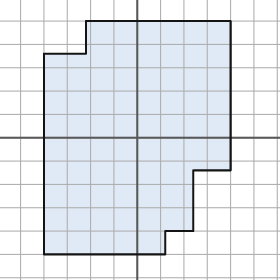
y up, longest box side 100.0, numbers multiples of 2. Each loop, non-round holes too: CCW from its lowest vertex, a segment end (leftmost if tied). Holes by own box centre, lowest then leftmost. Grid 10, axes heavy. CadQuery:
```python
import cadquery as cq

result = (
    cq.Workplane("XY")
    .moveTo(-40.0, -50.0)
    .lineTo(12.0, -50.0)
    .lineTo(12.0, -40.0)
    .lineTo(24.0, -40.0)
    .lineTo(24.0, -14.0)
    .lineTo(40.0, -14.0)
    .lineTo(40.0, 50.0)
    .lineTo(-22.0, 50.0)
    .lineTo(-22.0, 36.0)
    .lineTo(-40.0, 36.0)
    .close()
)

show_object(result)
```